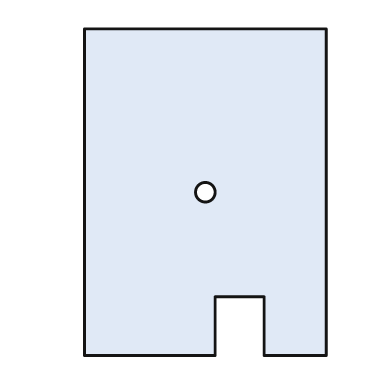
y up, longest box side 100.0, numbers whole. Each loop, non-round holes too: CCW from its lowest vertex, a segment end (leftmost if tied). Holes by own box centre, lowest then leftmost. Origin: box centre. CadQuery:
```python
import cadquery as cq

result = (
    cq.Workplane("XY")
    .moveTo(-37.0, -50.0)
    .lineTo(3.0, -50.0)
    .lineTo(3.0, -32.0)
    .lineTo(18.0, -32.0)
    .lineTo(18.0, -50.0)
    .lineTo(37.0, -50.0)
    .lineTo(37.0, 50.0)
    .lineTo(-37.0, 50.0)
    .close()
    .moveTo(0.0, 0.0)
    .circle(3.0)
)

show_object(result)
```